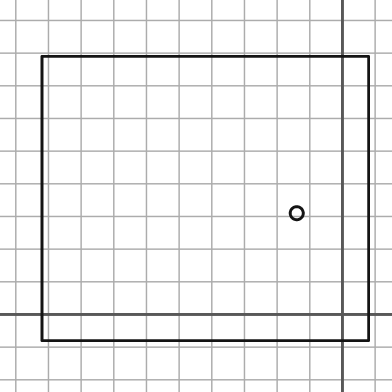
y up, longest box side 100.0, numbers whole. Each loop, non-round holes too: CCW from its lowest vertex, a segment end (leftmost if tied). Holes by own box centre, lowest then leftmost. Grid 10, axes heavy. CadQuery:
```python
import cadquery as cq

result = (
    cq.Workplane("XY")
    .moveTo(-92.0, -8.0)
    .lineTo(8.0, -8.0)
    .lineTo(8.0, 79.0)
    .lineTo(-92.0, 79.0)
    .close()
    .moveTo(-14.0, 31.0)
    .circle(2.0)
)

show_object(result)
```